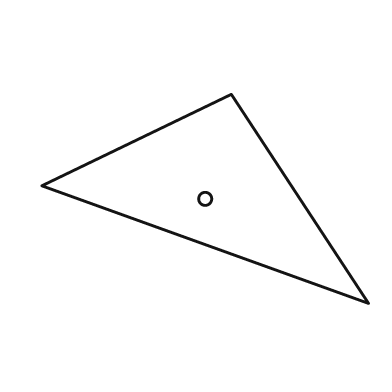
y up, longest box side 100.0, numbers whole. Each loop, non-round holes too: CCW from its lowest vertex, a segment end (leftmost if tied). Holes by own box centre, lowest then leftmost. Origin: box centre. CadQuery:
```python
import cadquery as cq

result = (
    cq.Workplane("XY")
    .moveTo(50.0, -32.0)
    .lineTo(8.0, 32.0)
    .lineTo(-50.0, 4.0)
    .close()
    .moveTo(0.0, 0.0)
    .circle(2.0)
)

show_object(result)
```